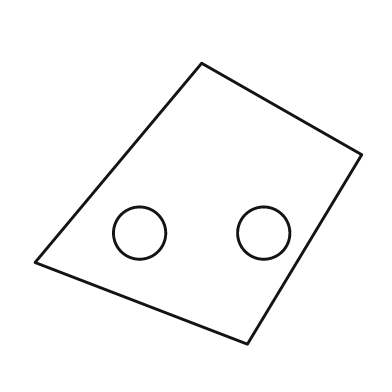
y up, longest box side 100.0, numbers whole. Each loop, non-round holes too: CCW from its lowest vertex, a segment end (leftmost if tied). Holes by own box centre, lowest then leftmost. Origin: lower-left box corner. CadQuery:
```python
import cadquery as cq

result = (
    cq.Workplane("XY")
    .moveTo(65.0, 0.0)
    .lineTo(100.0, 58.0)
    .lineTo(51.0, 86.0)
    .lineTo(0.0, 25.0)
    .close()
    .moveTo(32.0, 34.0)
    .circle(8.0)
    .moveTo(70.0, 34.0)
    .circle(8.0)
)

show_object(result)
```